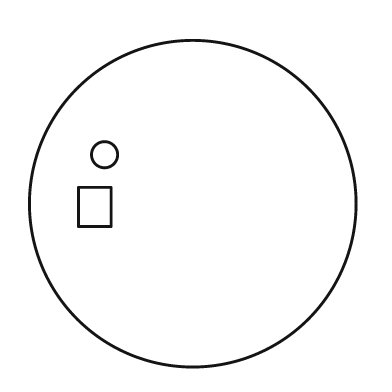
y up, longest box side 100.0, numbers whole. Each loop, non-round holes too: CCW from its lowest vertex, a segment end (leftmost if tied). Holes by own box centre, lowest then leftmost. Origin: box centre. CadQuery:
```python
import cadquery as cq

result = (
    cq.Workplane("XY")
    .moveTo(0.0, 0.0)
    .circle(50.0)
    .moveTo(-35.0, -7.0)
    .lineTo(-25.0, -7.0)
    .lineTo(-25.0, 5.0)
    .lineTo(-35.0, 5.0)
    .close()
    .moveTo(-27.0, 15.0)
    .circle(4.0)
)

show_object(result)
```